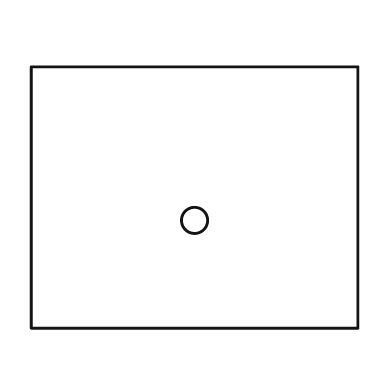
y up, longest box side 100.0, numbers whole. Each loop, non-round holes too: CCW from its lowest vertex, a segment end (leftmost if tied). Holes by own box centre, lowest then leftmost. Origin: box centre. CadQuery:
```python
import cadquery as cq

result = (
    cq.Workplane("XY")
    .moveTo(-50.0, -40.0)
    .lineTo(50.0, -40.0)
    .lineTo(50.0, 40.0)
    .lineTo(-50.0, 40.0)
    .close()
    .moveTo(0.0, -7.0)
    .circle(4.0)
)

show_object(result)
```